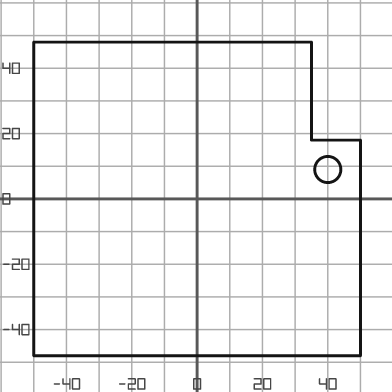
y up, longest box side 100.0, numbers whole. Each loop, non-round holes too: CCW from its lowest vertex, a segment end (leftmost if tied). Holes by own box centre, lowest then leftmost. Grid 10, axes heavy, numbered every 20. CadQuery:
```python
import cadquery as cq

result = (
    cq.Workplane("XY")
    .moveTo(-50.0, -48.0)
    .lineTo(50.0, -48.0)
    .lineTo(50.0, 18.0)
    .lineTo(35.0, 18.0)
    .lineTo(35.0, 48.0)
    .lineTo(-50.0, 48.0)
    .close()
    .moveTo(40.0, 9.0)
    .circle(4.0)
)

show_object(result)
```